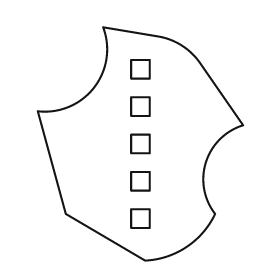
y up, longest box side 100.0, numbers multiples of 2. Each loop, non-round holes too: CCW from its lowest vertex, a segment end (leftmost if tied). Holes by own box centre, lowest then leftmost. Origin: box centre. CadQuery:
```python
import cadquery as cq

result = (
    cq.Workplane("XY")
    .moveTo(2.0, -50.0)
    .threePointArc((20.0, -44.0), (32.0, -30.0))
    .threePointArc((28.0, -8.0), (44.0, 8.0))
    .lineTo(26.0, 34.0)
    .threePointArc((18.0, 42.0), (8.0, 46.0))
    .lineTo(-16.0, 50.0)
    .threePointArc((-20.0, 24.0), (-44.0, 14.0))
    .lineTo(-32.0, -30.0)
    .close()
    .moveTo(-4.0, -36.0)
    .lineTo(4.0, -36.0)
    .lineTo(4.0, -28.0)
    .lineTo(-4.0, -28.0)
    .close()
    .moveTo(-4.0, -20.0)
    .lineTo(4.0, -20.0)
    .lineTo(4.0, -12.0)
    .lineTo(-4.0, -12.0)
    .close()
    .moveTo(-4.0, -4.0)
    .lineTo(4.0, -4.0)
    .lineTo(4.0, 4.0)
    .lineTo(-4.0, 4.0)
    .close()
    .moveTo(-4.0, 12.0)
    .lineTo(4.0, 12.0)
    .lineTo(4.0, 20.0)
    .lineTo(-4.0, 20.0)
    .close()
    .moveTo(-4.0, 28.0)
    .lineTo(4.0, 28.0)
    .lineTo(4.0, 36.0)
    .lineTo(-4.0, 36.0)
    .close()
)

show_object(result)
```